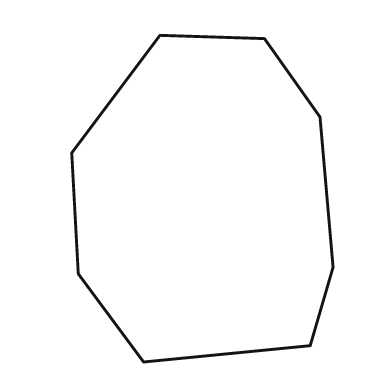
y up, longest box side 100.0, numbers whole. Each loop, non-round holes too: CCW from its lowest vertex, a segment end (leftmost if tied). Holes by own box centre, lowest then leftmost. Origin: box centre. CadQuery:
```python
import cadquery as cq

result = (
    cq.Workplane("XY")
    .moveTo(-18.0, -50.0)
    .lineTo(33.0, -45.0)
    .lineTo(40.0, -21.0)
    .lineTo(36.0, 25.0)
    .lineTo(19.0, 49.0)
    .lineTo(-13.0, 50.0)
    .lineTo(-40.0, 14.0)
    .lineTo(-38.0, -23.0)
    .close()
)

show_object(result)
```